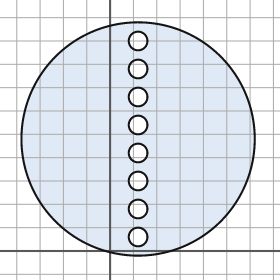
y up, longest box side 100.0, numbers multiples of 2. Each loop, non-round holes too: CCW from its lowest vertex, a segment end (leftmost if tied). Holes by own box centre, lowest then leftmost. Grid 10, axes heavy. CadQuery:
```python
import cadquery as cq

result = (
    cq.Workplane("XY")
    .moveTo(12.0, 48.0)
    .circle(50.0)
    .moveTo(12.0, 6.0)
    .circle(4.0)
    .moveTo(12.0, 18.0)
    .circle(4.0)
    .moveTo(12.0, 30.0)
    .circle(4.0)
    .moveTo(12.0, 42.0)
    .circle(4.0)
    .moveTo(12.0, 54.0)
    .circle(4.0)
    .moveTo(12.0, 66.0)
    .circle(4.0)
    .moveTo(12.0, 78.0)
    .circle(4.0)
    .moveTo(12.0, 90.0)
    .circle(4.0)
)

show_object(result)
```